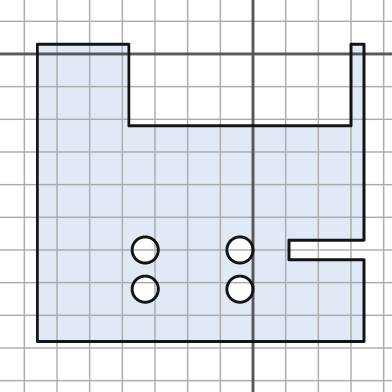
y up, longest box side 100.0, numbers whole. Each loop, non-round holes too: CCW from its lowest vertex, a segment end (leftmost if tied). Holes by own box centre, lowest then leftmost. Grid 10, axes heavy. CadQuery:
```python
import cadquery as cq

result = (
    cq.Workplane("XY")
    .moveTo(-66.0, -88.0)
    .lineTo(34.0, -88.0)
    .lineTo(34.0, -63.0)
    .lineTo(11.0, -63.0)
    .lineTo(11.0, -57.0)
    .lineTo(34.0, -57.0)
    .lineTo(34.0, 3.0)
    .lineTo(30.0, 3.0)
    .lineTo(30.0, -22.0)
    .lineTo(-38.0, -22.0)
    .lineTo(-38.0, 3.0)
    .lineTo(-66.0, 3.0)
    .close()
    .moveTo(-33.0, -72.0)
    .circle(4.0)
    .moveTo(-4.0, -72.0)
    .circle(4.0)
    .moveTo(-33.0, -60.0)
    .circle(4.0)
    .moveTo(-4.0, -60.0)
    .circle(4.0)
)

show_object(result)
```